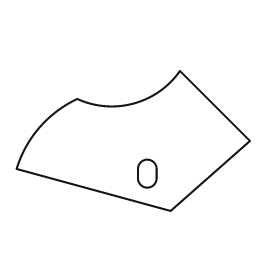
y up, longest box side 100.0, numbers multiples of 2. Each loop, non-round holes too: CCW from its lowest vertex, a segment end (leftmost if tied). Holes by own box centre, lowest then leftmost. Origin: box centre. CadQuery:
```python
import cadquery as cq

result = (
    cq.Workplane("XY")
    .moveTo(16.0, -30.0)
    .lineTo(50.0, 0.0)
    .lineTo(20.0, 30.0)
    .threePointArc((0.0, 16.0), (-24.0, 18.0))
    .threePointArc((-40.0, 6.0), (-50.0, -12.0))
    .close()
    .moveTo(2.0, -16.0)
    .threePointArc((6.0, -20.0), (10.0, -16.0))
    .lineTo(10.0, -12.0)
    .threePointArc((6.0, -8.0), (2.0, -12.0))
    .close()
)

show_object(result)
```